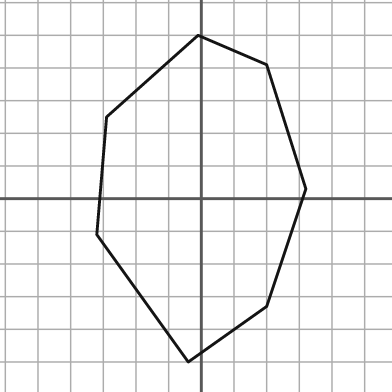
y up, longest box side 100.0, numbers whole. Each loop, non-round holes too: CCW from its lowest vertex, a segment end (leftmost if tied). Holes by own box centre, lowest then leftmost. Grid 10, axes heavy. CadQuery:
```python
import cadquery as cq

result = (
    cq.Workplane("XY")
    .moveTo(-4.0, -50.0)
    .lineTo(20.0, -33.0)
    .lineTo(32.0, 3.0)
    .lineTo(20.0, 41.0)
    .lineTo(-1.0, 50.0)
    .lineTo(-29.0, 25.0)
    .lineTo(-32.0, -11.0)
    .close()
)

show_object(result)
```